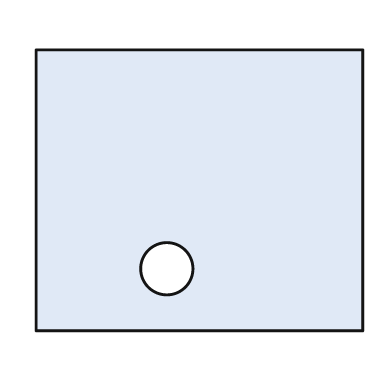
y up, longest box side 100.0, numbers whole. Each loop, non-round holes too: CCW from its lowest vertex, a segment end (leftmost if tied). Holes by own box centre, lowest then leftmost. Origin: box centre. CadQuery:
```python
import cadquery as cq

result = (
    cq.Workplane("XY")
    .moveTo(-50.0, -43.0)
    .lineTo(50.0, -43.0)
    .lineTo(50.0, 43.0)
    .lineTo(-50.0, 43.0)
    .close()
    .moveTo(-10.0, -24.0)
    .circle(8.0)
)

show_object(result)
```